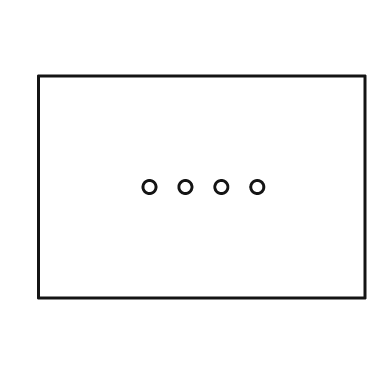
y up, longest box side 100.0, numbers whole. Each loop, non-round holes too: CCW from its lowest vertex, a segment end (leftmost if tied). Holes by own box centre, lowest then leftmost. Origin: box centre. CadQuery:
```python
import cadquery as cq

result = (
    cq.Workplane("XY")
    .moveTo(-50.0, -34.0)
    .lineTo(50.0, -34.0)
    .lineTo(50.0, 34.0)
    .lineTo(-50.0, 34.0)
    .close()
    .moveTo(-16.0, 0.0)
    .circle(2.0)
    .moveTo(-5.0, 0.0)
    .circle(2.0)
    .moveTo(6.0, 0.0)
    .circle(2.0)
    .moveTo(17.0, 0.0)
    .circle(2.0)
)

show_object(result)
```